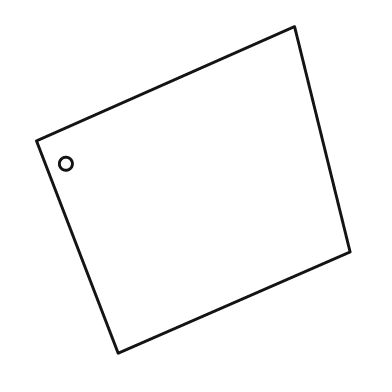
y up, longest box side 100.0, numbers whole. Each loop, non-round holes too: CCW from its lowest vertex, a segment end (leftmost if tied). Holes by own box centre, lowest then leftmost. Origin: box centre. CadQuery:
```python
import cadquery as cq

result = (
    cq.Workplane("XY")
    .moveTo(-23.0, -50.0)
    .lineTo(48.0, -19.0)
    .lineTo(31.0, 50.0)
    .lineTo(-48.0, 15.0)
    .close()
    .moveTo(-39.0, 8.0)
    .circle(2.0)
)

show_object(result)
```